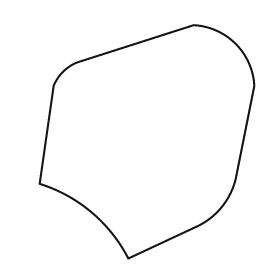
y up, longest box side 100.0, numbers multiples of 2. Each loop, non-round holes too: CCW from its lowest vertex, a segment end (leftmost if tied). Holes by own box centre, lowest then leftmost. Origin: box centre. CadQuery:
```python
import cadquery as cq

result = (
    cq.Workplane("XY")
    .moveTo(-8.0, -50.0)
    .lineTo(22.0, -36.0)
    .threePointArc((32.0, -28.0), (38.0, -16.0))
    .lineTo(46.0, 24.0)
    .threePointArc((38.0, 42.0), (20.0, 50.0))
    .lineTo(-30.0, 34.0)
    .threePointArc((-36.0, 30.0), (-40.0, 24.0))
    .lineTo(-46.0, -18.0)
    .threePointArc((-24.0, -30.0), (-8.0, -50.0))
    .close()
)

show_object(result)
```